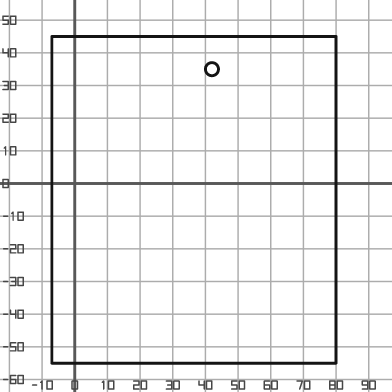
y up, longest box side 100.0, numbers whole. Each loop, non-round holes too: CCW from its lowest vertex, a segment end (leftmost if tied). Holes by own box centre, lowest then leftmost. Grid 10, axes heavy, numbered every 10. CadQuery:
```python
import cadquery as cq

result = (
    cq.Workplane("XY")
    .moveTo(-7.0, -55.0)
    .lineTo(80.0, -55.0)
    .lineTo(80.0, 45.0)
    .lineTo(-7.0, 45.0)
    .close()
    .moveTo(42.0, 35.0)
    .circle(2.0)
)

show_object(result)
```